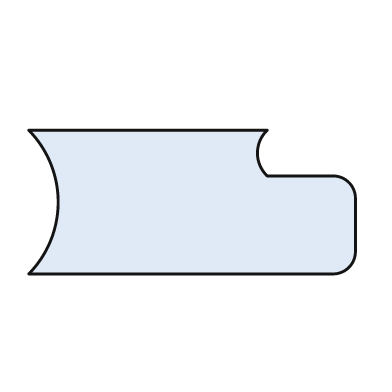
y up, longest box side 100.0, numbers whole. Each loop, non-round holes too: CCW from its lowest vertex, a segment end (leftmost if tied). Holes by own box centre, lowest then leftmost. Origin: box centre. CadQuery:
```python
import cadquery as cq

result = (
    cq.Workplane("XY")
    .moveTo(-50.0, -22.0)
    .lineTo(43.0, -22.0)
    .threePointArc((48.0, -20.0), (50.0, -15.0))
    .lineTo(50.0, 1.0)
    .threePointArc((48.0, 6.0), (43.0, 8.0))
    .lineTo(23.0, 8.0)
    .threePointArc((20.0, 15.0), (23.0, 22.0))
    .lineTo(-50.0, 22.0)
    .threePointArc((-41.0, 0.0), (-50.0, -22.0))
    .close()
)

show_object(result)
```